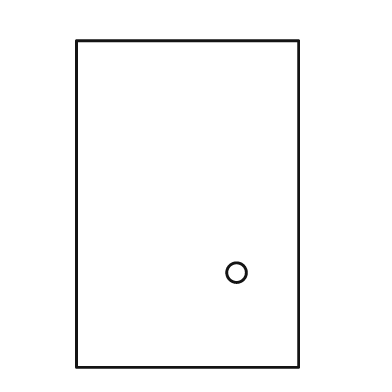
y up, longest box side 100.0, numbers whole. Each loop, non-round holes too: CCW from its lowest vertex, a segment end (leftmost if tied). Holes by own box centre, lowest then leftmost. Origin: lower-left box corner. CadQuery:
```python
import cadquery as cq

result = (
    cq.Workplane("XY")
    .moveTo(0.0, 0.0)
    .lineTo(68.0, 0.0)
    .lineTo(68.0, 100.0)
    .lineTo(0.0, 100.0)
    .close()
    .moveTo(49.0, 29.0)
    .circle(3.0)
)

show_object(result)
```